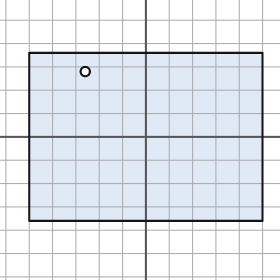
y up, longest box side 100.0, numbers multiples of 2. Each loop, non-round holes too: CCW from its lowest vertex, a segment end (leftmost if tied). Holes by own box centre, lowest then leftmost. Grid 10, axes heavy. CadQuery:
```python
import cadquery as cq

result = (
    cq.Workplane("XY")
    .moveTo(-50.0, -36.0)
    .lineTo(50.0, -36.0)
    .lineTo(50.0, 36.0)
    .lineTo(-50.0, 36.0)
    .close()
    .moveTo(-26.0, 28.0)
    .circle(2.0)
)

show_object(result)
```